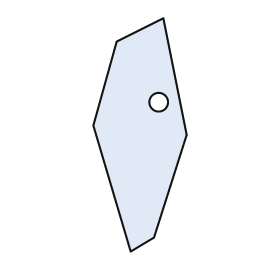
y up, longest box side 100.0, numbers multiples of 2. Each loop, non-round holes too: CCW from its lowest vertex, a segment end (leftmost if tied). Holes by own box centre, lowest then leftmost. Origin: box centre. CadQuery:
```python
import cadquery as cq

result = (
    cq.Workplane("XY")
    .moveTo(-4.0, -50.0)
    .lineTo(6.0, -44.0)
    .lineTo(20.0, 0.0)
    .lineTo(10.0, 50.0)
    .lineTo(-10.0, 40.0)
    .lineTo(-20.0, 4.0)
    .close()
    .moveTo(8.0, 14.0)
    .circle(4.0)
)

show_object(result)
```